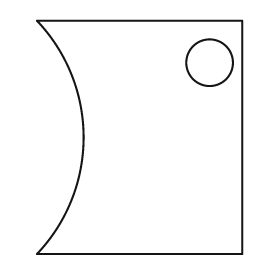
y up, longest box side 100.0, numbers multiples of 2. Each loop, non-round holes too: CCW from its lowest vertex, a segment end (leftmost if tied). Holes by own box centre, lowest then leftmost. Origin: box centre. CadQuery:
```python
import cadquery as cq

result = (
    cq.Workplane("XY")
    .moveTo(-44.0, -50.0)
    .lineTo(44.0, -50.0)
    .lineTo(44.0, 50.0)
    .lineTo(-44.0, 50.0)
    .threePointArc((-24.0, 0.0), (-44.0, -50.0))
    .close()
    .moveTo(30.0, 32.0)
    .circle(10.0)
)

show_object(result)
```